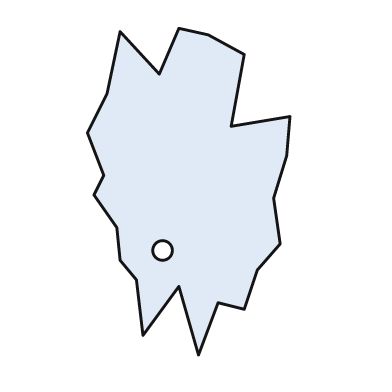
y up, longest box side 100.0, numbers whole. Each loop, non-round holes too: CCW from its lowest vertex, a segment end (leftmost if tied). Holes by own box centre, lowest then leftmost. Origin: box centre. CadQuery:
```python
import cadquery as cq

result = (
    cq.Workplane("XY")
    .moveTo(3.0, -50.0)
    .lineTo(9.0, -34.0)
    .lineTo(17.0, -36.0)
    .lineTo(21.0, -24.0)
    .lineTo(28.0, -16.0)
    .lineTo(26.0, -2.0)
    .lineTo(30.0, 11.0)
    .lineTo(31.0, 23.0)
    .lineTo(13.0, 20.0)
    .lineTo(17.0, 42.0)
    .lineTo(6.0, 48.0)
    .lineTo(-3.0, 50.0)
    .lineTo(-9.0, 36.0)
    .lineTo(-21.0, 49.0)
    .lineTo(-25.0, 30.0)
    .lineTo(-31.0, 18.0)
    .lineTo(-26.0, 5.0)
    .lineTo(-29.0, -1.0)
    .lineTo(-22.0, -11.0)
    .lineTo(-21.0, -21.0)
    .lineTo(-16.0, -27.0)
    .lineTo(-14.0, -44.0)
    .lineTo(-3.0, -29.0)
    .close()
    .moveTo(-8.0, -18.0)
    .circle(3.0)
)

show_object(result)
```